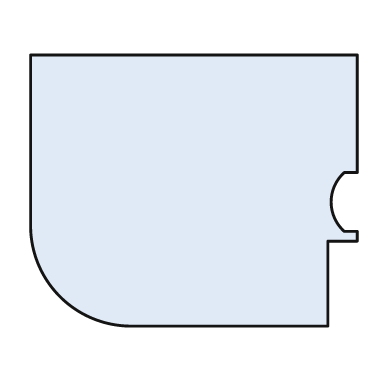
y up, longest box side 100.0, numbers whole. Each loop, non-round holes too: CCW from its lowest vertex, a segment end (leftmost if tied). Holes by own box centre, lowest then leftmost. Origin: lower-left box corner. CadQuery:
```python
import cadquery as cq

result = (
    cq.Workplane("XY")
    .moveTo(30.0, 0.0)
    .lineTo(91.0, 0.0)
    .lineTo(91.0, 26.0)
    .lineTo(100.0, 26.0)
    .lineTo(100.0, 29.0)
    .lineTo(96.0, 29.0)
    .threePointArc((92.0, 38.0), (96.0, 47.0))
    .lineTo(100.0, 47.0)
    .lineTo(100.0, 83.0)
    .lineTo(0.0, 83.0)
    .lineTo(0.0, 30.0)
    .threePointArc((9.0, 9.0), (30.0, 0.0))
    .close()
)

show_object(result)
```